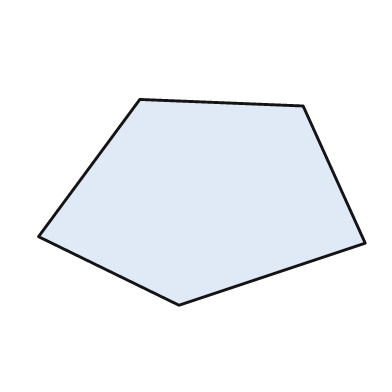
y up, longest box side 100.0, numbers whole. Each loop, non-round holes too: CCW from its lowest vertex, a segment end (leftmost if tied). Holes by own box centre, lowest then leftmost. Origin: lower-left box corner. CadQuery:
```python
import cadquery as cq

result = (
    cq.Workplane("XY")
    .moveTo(43.0, 0.0)
    .lineTo(100.0, 19.0)
    .lineTo(81.0, 61.0)
    .lineTo(31.0, 63.0)
    .lineTo(0.0, 21.0)
    .close()
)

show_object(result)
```